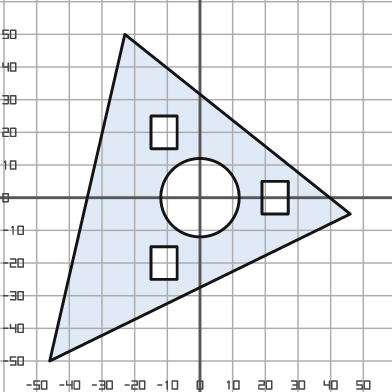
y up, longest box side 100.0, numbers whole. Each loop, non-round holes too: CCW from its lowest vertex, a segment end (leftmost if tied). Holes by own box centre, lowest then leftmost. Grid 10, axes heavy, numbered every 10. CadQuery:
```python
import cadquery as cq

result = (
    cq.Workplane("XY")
    .moveTo(-46.0, -50.0)
    .lineTo(46.0, -5.0)
    .lineTo(-23.0, 50.0)
    .close()
    .moveTo(-15.0, -25.0)
    .lineTo(-7.0, -25.0)
    .lineTo(-7.0, -15.0)
    .lineTo(-15.0, -15.0)
    .close()
    .moveTo(0.0, 0.0)
    .circle(12.0)
    .moveTo(19.0, -5.0)
    .lineTo(27.0, -5.0)
    .lineTo(27.0, 5.0)
    .lineTo(19.0, 5.0)
    .close()
    .moveTo(-15.0, 15.0)
    .lineTo(-7.0, 15.0)
    .lineTo(-7.0, 25.0)
    .lineTo(-15.0, 25.0)
    .close()
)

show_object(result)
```